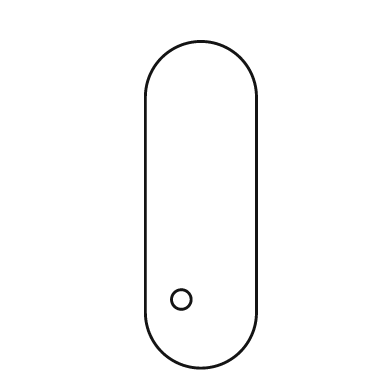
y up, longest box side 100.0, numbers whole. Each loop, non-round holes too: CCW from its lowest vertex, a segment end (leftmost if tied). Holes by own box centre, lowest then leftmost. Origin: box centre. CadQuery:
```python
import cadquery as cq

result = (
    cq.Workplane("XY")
    .moveTo(-17.0, -33.0)
    .threePointArc((0.0, -50.0), (17.0, -33.0))
    .lineTo(17.0, 33.0)
    .threePointArc((0.0, 50.0), (-17.0, 33.0))
    .close()
    .moveTo(-6.0, -29.0)
    .circle(3.0)
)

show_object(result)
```